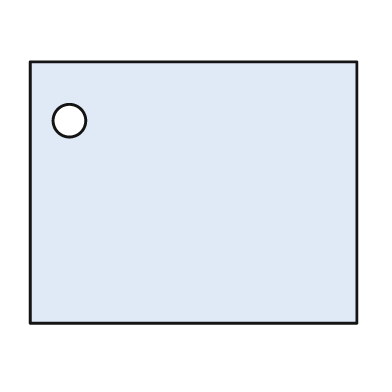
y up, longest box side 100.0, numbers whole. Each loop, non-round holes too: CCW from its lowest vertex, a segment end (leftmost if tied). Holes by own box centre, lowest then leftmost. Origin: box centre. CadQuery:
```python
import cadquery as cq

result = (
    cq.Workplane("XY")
    .moveTo(-50.0, -40.0)
    .lineTo(50.0, -40.0)
    .lineTo(50.0, 40.0)
    .lineTo(-50.0, 40.0)
    .close()
    .moveTo(-38.0, 22.0)
    .circle(5.0)
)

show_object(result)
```